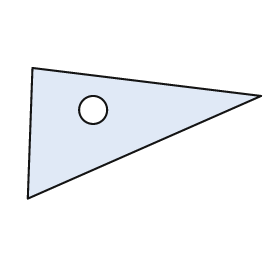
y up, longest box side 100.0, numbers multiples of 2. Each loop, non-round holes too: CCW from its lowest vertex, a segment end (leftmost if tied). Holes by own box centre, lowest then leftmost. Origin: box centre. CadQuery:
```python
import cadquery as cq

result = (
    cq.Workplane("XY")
    .moveTo(-50.0, -28.0)
    .lineTo(50.0, 16.0)
    .lineTo(-48.0, 28.0)
    .close()
    .moveTo(-22.0, 10.0)
    .circle(6.0)
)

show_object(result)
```